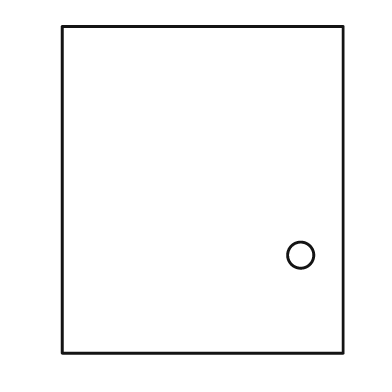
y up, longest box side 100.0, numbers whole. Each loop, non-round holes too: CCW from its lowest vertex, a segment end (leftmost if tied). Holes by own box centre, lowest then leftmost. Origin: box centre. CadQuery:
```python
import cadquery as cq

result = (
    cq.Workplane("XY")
    .moveTo(-43.0, -50.0)
    .lineTo(43.0, -50.0)
    .lineTo(43.0, 50.0)
    .lineTo(-43.0, 50.0)
    .close()
    .moveTo(30.0, -20.0)
    .circle(4.0)
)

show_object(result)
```